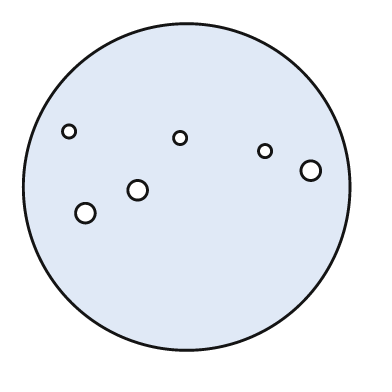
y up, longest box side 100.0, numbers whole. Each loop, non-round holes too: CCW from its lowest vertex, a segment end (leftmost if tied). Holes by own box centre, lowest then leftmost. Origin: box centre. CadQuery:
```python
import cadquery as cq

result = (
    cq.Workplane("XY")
    .moveTo(0.0, 0.0)
    .circle(50.0)
    .moveTo(-31.0, -8.0)
    .circle(3.0)
    .moveTo(-15.0, -1.0)
    .circle(3.0)
    .moveTo(38.0, 5.0)
    .circle(3.0)
    .moveTo(24.0, 11.0)
    .circle(2.0)
    .moveTo(-2.0, 15.0)
    .circle(2.0)
    .moveTo(-36.0, 17.0)
    .circle(2.0)
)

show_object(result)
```